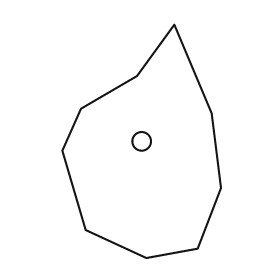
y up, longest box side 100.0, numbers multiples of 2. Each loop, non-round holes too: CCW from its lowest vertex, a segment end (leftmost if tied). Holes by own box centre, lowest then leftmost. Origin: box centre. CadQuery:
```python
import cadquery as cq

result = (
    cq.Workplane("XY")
    .moveTo(2.0, -50.0)
    .lineTo(24.0, -46.0)
    .lineTo(34.0, -20.0)
    .lineTo(30.0, 12.0)
    .lineTo(14.0, 50.0)
    .lineTo(-2.0, 28.0)
    .lineTo(-26.0, 14.0)
    .lineTo(-34.0, -4.0)
    .lineTo(-24.0, -38.0)
    .close()
    .moveTo(0.0, 0.0)
    .circle(4.0)
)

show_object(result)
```